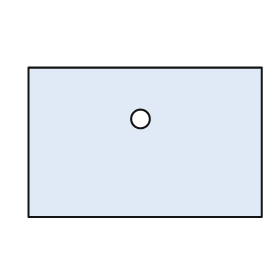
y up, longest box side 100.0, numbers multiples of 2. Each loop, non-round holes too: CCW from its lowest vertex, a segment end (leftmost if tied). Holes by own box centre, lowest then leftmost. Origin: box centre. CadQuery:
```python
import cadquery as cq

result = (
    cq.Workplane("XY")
    .moveTo(-50.0, -32.0)
    .lineTo(50.0, -32.0)
    .lineTo(50.0, 32.0)
    .lineTo(-50.0, 32.0)
    .close()
    .moveTo(-2.0, 10.0)
    .circle(4.0)
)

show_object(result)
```